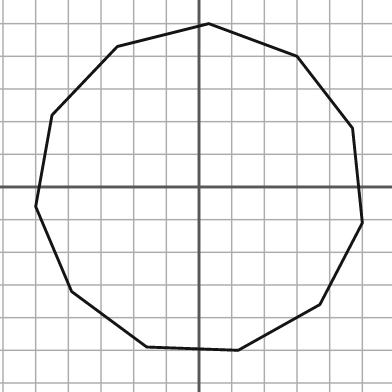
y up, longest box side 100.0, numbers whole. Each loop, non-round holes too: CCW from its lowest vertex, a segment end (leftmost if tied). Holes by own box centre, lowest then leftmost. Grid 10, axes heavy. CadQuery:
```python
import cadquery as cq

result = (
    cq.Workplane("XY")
    .moveTo(12.0, -50.0)
    .lineTo(37.0, -36.0)
    .lineTo(50.0, -11.0)
    .lineTo(47.0, 18.0)
    .lineTo(30.0, 40.0)
    .lineTo(3.0, 50.0)
    .lineTo(-25.0, 43.0)
    .lineTo(-45.0, 22.0)
    .lineTo(-50.0, -6.0)
    .lineTo(-39.0, -32.0)
    .lineTo(-16.0, -49.0)
    .close()
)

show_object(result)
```